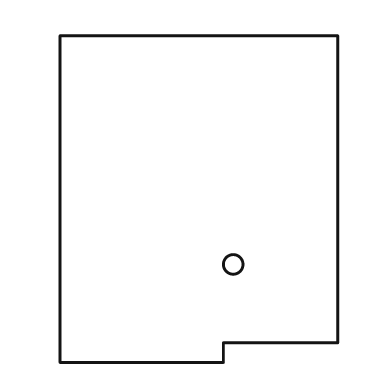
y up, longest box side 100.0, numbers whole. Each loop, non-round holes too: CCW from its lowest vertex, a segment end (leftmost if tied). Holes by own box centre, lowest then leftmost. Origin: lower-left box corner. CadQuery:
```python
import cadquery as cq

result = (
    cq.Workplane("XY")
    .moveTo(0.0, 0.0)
    .lineTo(50.0, 0.0)
    .lineTo(50.0, 6.0)
    .lineTo(85.0, 6.0)
    .lineTo(85.0, 100.0)
    .lineTo(0.0, 100.0)
    .close()
    .moveTo(53.0, 30.0)
    .circle(3.0)
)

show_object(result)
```